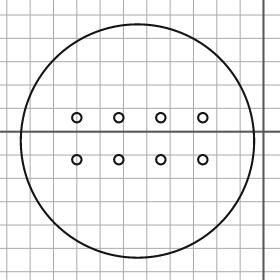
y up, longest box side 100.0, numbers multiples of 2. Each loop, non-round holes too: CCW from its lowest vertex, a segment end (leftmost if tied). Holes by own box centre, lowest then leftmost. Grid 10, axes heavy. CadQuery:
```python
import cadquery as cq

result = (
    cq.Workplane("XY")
    .moveTo(-54.0, -4.0)
    .circle(50.0)
    .moveTo(-80.0, -12.0)
    .circle(2.0)
    .moveTo(-62.0, -12.0)
    .circle(2.0)
    .moveTo(-44.0, -12.0)
    .circle(2.0)
    .moveTo(-26.0, -12.0)
    .circle(2.0)
    .moveTo(-80.0, 6.0)
    .circle(2.0)
    .moveTo(-62.0, 6.0)
    .circle(2.0)
    .moveTo(-44.0, 6.0)
    .circle(2.0)
    .moveTo(-26.0, 6.0)
    .circle(2.0)
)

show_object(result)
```